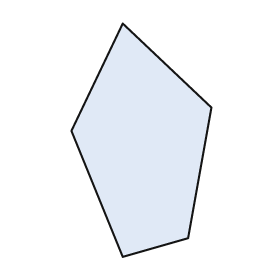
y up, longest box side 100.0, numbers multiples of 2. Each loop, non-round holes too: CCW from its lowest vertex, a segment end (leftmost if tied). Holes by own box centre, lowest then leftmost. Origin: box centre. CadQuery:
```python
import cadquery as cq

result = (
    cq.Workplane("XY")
    .moveTo(-8.0, -50.0)
    .lineTo(20.0, -42.0)
    .lineTo(30.0, 14.0)
    .lineTo(-8.0, 50.0)
    .lineTo(-30.0, 4.0)
    .close()
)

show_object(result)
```